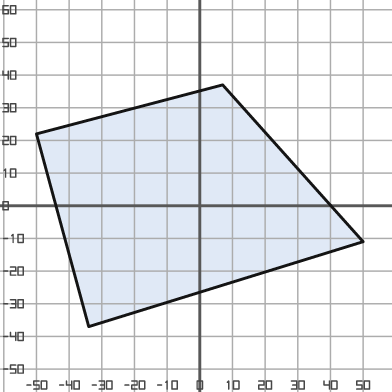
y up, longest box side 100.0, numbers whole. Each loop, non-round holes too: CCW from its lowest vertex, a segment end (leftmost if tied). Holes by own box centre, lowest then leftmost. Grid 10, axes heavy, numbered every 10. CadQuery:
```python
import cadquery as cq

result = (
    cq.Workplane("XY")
    .moveTo(-34.0, -37.0)
    .lineTo(50.0, -11.0)
    .lineTo(7.0, 37.0)
    .lineTo(-50.0, 22.0)
    .close()
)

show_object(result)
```